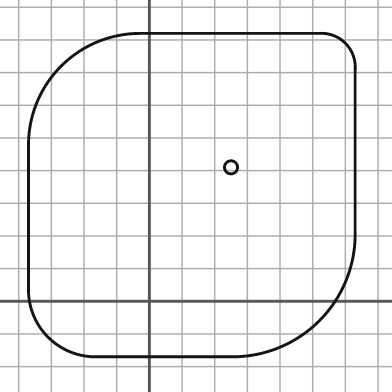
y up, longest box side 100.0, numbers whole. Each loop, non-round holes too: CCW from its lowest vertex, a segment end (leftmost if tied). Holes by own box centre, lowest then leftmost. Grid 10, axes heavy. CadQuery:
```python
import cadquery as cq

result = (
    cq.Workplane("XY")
    .moveTo(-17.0, -17.0)
    .lineTo(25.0, -17.0)
    .threePointArc((52.0, -6.0), (63.0, 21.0))
    .lineTo(63.0, 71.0)
    .threePointArc((60.0, 79.0), (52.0, 82.0))
    .lineTo(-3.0, 82.0)
    .threePointArc((-27.0, 72.0), (-37.0, 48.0))
    .lineTo(-37.0, 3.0)
    .threePointArc((-31.0, -11.0), (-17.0, -17.0))
    .close()
    .moveTo(25.0, 41.0)
    .circle(2.0)
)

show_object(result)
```